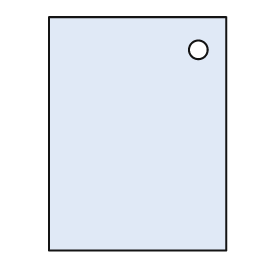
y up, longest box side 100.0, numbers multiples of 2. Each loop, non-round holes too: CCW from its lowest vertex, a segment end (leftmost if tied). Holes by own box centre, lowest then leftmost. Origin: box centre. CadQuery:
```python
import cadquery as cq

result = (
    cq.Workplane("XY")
    .moveTo(-38.0, -50.0)
    .lineTo(38.0, -50.0)
    .lineTo(38.0, 50.0)
    .lineTo(-38.0, 50.0)
    .close()
    .moveTo(26.0, 36.0)
    .circle(4.0)
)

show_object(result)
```